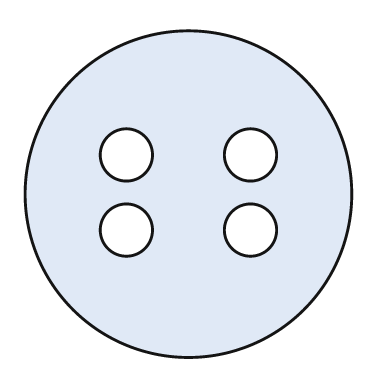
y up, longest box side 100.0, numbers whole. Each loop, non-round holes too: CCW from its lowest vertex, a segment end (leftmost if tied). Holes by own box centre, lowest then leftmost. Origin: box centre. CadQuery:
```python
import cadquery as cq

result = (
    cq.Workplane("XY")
    .moveTo(0.0, 0.0)
    .circle(50.0)
    .moveTo(-19.0, -11.0)
    .circle(8.0)
    .moveTo(19.0, -11.0)
    .circle(8.0)
    .moveTo(-19.0, 12.0)
    .circle(8.0)
    .moveTo(19.0, 12.0)
    .circle(8.0)
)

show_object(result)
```